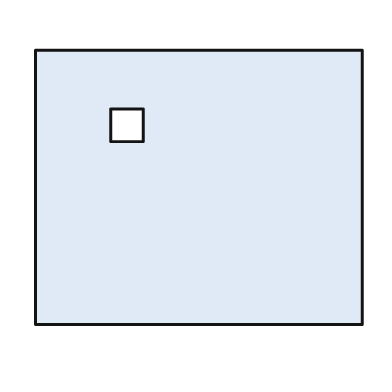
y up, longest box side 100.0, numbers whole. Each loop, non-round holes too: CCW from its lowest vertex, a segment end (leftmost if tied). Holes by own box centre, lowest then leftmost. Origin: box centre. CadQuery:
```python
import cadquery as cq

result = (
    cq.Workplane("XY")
    .moveTo(-50.0, -42.0)
    .lineTo(50.0, -42.0)
    .lineTo(50.0, 42.0)
    .lineTo(-50.0, 42.0)
    .close()
    .moveTo(-27.0, 14.0)
    .lineTo(-17.0, 14.0)
    .lineTo(-17.0, 24.0)
    .lineTo(-27.0, 24.0)
    .close()
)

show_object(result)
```